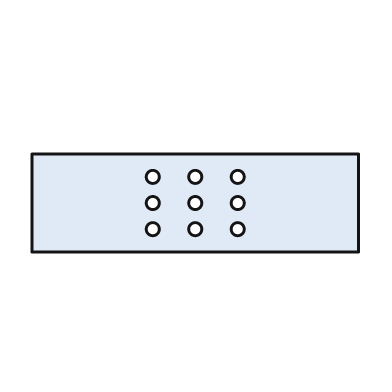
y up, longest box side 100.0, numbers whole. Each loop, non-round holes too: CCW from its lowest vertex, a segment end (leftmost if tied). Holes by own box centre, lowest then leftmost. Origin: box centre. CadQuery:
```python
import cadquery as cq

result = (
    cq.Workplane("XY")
    .moveTo(-50.0, -15.0)
    .lineTo(50.0, -15.0)
    .lineTo(50.0, 15.0)
    .lineTo(-50.0, 15.0)
    .close()
    .moveTo(-13.0, -8.0)
    .circle(2.0)
    .moveTo(0.0, -8.0)
    .circle(2.0)
    .moveTo(13.0, -8.0)
    .circle(2.0)
    .moveTo(-13.0, 0.0)
    .circle(2.0)
    .moveTo(0.0, 0.0)
    .circle(2.0)
    .moveTo(13.0, 0.0)
    .circle(2.0)
    .moveTo(-13.0, 8.0)
    .circle(2.0)
    .moveTo(0.0, 8.0)
    .circle(2.0)
    .moveTo(13.0, 8.0)
    .circle(2.0)
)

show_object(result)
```